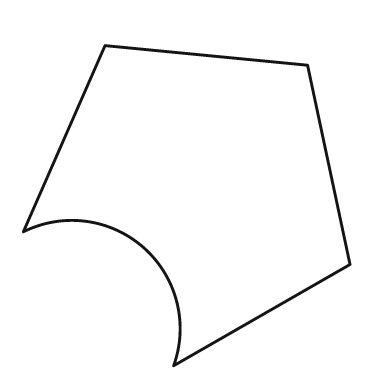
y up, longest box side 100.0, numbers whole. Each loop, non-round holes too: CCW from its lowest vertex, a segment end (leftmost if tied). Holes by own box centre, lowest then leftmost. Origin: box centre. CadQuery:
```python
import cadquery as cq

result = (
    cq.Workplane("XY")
    .moveTo(-4.0, -49.0)
    .lineTo(50.0, -18.0)
    .lineTo(37.0, 43.0)
    .lineTo(-25.0, 49.0)
    .lineTo(-50.0, -8.0)
    .threePointArc((-13.0, -13.0), (-4.0, -49.0))
    .close()
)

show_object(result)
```